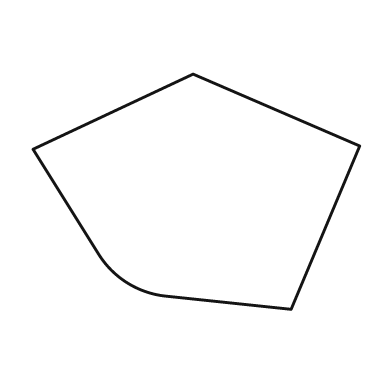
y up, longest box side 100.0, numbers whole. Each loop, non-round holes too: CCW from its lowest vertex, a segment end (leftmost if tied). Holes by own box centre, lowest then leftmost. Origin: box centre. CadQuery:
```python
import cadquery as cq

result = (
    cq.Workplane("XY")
    .moveTo(29.0, -36.0)
    .lineTo(50.0, 14.0)
    .lineTo(-1.0, 36.0)
    .lineTo(-50.0, 13.0)
    .lineTo(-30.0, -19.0)
    .threePointArc((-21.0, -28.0), (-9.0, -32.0))
    .close()
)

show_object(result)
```